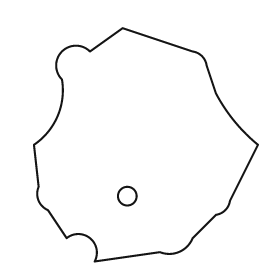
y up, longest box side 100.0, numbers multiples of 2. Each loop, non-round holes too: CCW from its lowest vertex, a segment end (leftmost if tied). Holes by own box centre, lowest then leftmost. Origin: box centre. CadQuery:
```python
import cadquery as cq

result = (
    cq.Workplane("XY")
    .moveTo(-22.0, -50.0)
    .lineTo(6.0, -46.0)
    .threePointArc((14.0, -46.0), (20.0, -40.0))
    .lineTo(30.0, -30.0)
    .threePointArc((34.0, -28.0), (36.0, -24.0))
    .lineTo(48.0, 0.0)
    .threePointArc((38.0, 10.0), (30.0, 22.0))
    .lineTo(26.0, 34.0)
    .threePointArc((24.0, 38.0), (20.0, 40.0))
    .lineTo(-10.0, 50.0)
    .lineTo(-24.0, 40.0)
    .threePointArc((-36.0, 40.0), (-36.0, 28.0))
    .threePointArc((-38.0, 12.0), (-48.0, 0.0))
    .lineTo(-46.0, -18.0)
    .threePointArc((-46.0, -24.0), (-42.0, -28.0))
    .lineTo(-34.0, -40.0)
    .threePointArc((-24.0, -40.0), (-22.0, -50.0))
    .close()
    .moveTo(-8.0, -22.0)
    .circle(4.0)
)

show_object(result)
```